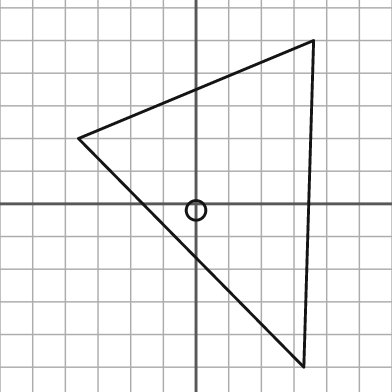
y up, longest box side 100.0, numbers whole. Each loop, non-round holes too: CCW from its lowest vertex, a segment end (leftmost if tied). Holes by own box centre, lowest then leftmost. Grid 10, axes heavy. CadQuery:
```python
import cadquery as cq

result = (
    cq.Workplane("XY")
    .moveTo(33.0, -50.0)
    .lineTo(36.0, 50.0)
    .lineTo(-36.0, 20.0)
    .close()
    .moveTo(0.0, -2.0)
    .circle(3.0)
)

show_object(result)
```